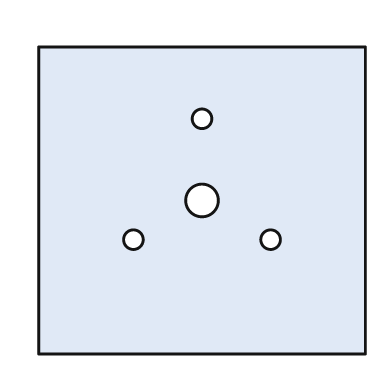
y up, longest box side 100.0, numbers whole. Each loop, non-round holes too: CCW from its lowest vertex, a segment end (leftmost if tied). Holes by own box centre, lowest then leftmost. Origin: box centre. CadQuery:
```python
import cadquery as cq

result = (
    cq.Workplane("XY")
    .moveTo(-50.0, -47.0)
    .lineTo(50.0, -47.0)
    .lineTo(50.0, 47.0)
    .lineTo(-50.0, 47.0)
    .close()
    .moveTo(-21.0, -12.0)
    .circle(3.0)
    .moveTo(21.0, -12.0)
    .circle(3.0)
    .moveTo(0.0, 0.0)
    .circle(5.0)
    .moveTo(0.0, 25.0)
    .circle(3.0)
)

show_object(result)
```